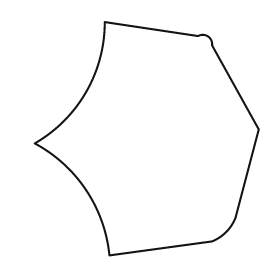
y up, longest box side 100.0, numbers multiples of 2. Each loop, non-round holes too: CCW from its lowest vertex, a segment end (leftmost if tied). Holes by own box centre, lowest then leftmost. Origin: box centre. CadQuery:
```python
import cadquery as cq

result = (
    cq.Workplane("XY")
    .moveTo(-16.0, -50.0)
    .lineTo(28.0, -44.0)
    .threePointArc((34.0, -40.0), (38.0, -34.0))
    .lineTo(48.0, 4.0)
    .lineTo(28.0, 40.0)
    .threePointArc((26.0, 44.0), (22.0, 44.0))
    .lineTo(-18.0, 50.0)
    .threePointArc((-26.0, 20.0), (-48.0, -2.0))
    .threePointArc((-26.0, -22.0), (-16.0, -50.0))
    .close()
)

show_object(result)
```